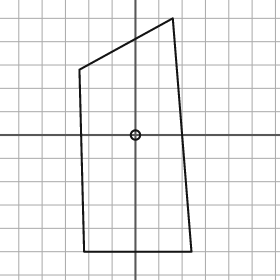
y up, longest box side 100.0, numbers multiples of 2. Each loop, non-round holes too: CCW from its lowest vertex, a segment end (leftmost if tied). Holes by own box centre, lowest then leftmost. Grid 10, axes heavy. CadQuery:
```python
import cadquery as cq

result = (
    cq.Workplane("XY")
    .moveTo(-22.0, -50.0)
    .lineTo(24.0, -50.0)
    .lineTo(16.0, 50.0)
    .lineTo(-24.0, 28.0)
    .close()
    .moveTo(0.0, 0.0)
    .circle(2.0)
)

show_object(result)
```